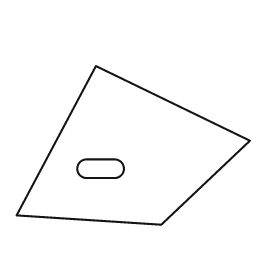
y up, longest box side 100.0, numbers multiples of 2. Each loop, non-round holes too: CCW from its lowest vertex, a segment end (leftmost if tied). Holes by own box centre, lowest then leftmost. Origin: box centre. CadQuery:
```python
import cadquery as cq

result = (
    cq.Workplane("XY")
    .moveTo(12.0, -34.0)
    .lineTo(50.0, 2.0)
    .lineTo(-16.0, 34.0)
    .lineTo(-50.0, -30.0)
    .close()
    .moveTo(-20.0, -14.0)
    .lineTo(-8.0, -14.0)
    .threePointArc((-4.0, -10.0), (-8.0, -6.0))
    .lineTo(-20.0, -6.0)
    .threePointArc((-24.0, -10.0), (-20.0, -14.0))
    .close()
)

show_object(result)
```